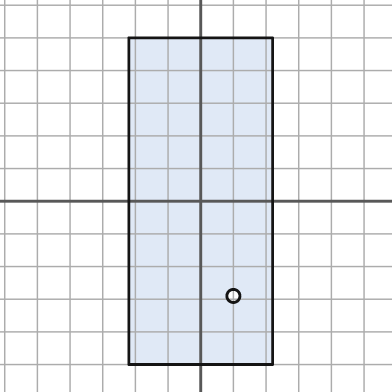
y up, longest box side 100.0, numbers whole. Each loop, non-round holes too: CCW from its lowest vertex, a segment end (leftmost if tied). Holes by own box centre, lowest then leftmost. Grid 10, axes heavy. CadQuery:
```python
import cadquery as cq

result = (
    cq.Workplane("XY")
    .moveTo(-22.0, -50.0)
    .lineTo(22.0, -50.0)
    .lineTo(22.0, 50.0)
    .lineTo(-22.0, 50.0)
    .close()
    .moveTo(10.0, -29.0)
    .circle(2.0)
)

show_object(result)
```